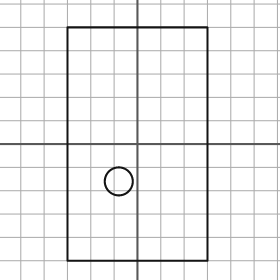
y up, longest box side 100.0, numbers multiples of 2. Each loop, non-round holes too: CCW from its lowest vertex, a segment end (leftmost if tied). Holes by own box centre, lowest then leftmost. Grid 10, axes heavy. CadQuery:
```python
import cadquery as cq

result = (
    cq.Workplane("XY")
    .moveTo(-30.0, -50.0)
    .lineTo(30.0, -50.0)
    .lineTo(30.0, 50.0)
    .lineTo(-30.0, 50.0)
    .close()
    .moveTo(-8.0, -16.0)
    .circle(6.0)
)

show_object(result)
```